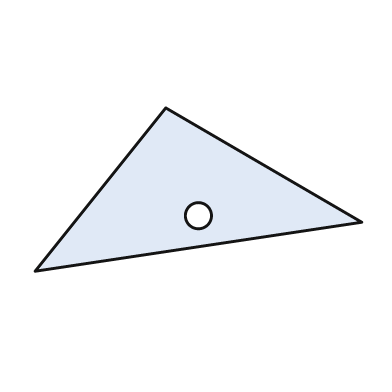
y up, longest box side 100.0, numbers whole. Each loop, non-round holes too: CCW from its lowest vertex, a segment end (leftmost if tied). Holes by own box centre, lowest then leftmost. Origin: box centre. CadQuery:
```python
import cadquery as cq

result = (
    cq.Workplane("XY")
    .moveTo(-50.0, -25.0)
    .lineTo(50.0, -10.0)
    .lineTo(-10.0, 25.0)
    .close()
    .moveTo(0.0, -8.0)
    .circle(4.0)
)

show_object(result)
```